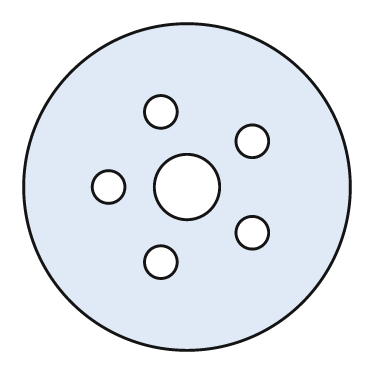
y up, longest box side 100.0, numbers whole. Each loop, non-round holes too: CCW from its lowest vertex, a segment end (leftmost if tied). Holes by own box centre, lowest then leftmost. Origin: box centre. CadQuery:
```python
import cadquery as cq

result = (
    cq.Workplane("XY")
    .moveTo(0.0, 0.0)
    .circle(50.0)
    .moveTo(-8.0, -23.0)
    .circle(5.0)
    .moveTo(20.0, -14.0)
    .circle(5.0)
    .moveTo(-24.0, 0.0)
    .circle(5.0)
    .moveTo(0.0, 0.0)
    .circle(10.0)
    .moveTo(20.0, 14.0)
    .circle(5.0)
    .moveTo(-8.0, 23.0)
    .circle(5.0)
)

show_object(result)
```